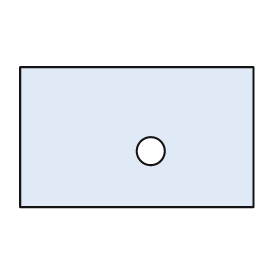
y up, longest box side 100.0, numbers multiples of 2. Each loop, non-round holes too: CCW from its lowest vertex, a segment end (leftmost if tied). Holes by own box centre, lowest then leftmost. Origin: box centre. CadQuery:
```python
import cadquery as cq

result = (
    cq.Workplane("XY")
    .moveTo(-50.0, -30.0)
    .lineTo(50.0, -30.0)
    .lineTo(50.0, 30.0)
    .lineTo(-50.0, 30.0)
    .close()
    .moveTo(6.0, -6.0)
    .circle(6.0)
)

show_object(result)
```